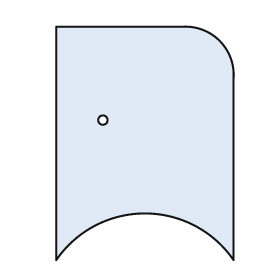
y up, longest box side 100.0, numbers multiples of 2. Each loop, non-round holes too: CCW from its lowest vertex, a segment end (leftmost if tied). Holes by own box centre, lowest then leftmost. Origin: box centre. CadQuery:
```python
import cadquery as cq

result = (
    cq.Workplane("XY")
    .moveTo(-38.0, -50.0)
    .threePointArc((0.0, -30.0), (38.0, -50.0))
    .lineTo(38.0, 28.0)
    .threePointArc((32.0, 44.0), (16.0, 50.0))
    .lineTo(-38.0, 50.0)
    .close()
    .moveTo(-18.0, 10.0)
    .circle(2.0)
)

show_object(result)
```